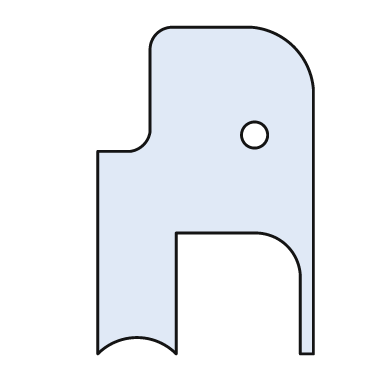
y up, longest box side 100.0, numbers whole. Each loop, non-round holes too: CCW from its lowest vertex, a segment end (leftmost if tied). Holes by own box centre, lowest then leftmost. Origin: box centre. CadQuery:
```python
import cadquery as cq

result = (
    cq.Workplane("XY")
    .moveTo(-33.0, -50.0)
    .threePointArc((-21.0, -45.0), (-9.0, -50.0))
    .lineTo(-9.0, -13.0)
    .lineTo(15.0, -13.0)
    .threePointArc((25.0, -17.0), (29.0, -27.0))
    .lineTo(29.0, -50.0)
    .lineTo(33.0, -50.0)
    .lineTo(33.0, 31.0)
    .threePointArc((27.0, 44.0), (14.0, 50.0))
    .lineTo(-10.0, 50.0)
    .threePointArc((-15.0, 48.0), (-17.0, 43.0))
    .lineTo(-17.0, 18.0)
    .threePointArc((-19.0, 14.0), (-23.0, 12.0))
    .lineTo(-33.0, 12.0)
    .close()
    .moveTo(15.0, 17.0)
    .circle(4.0)
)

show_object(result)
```